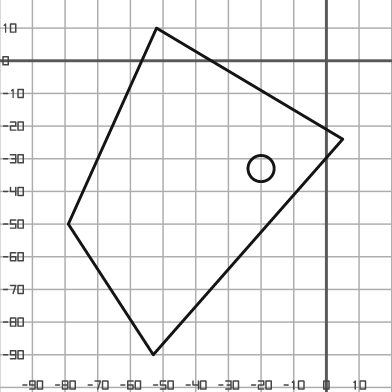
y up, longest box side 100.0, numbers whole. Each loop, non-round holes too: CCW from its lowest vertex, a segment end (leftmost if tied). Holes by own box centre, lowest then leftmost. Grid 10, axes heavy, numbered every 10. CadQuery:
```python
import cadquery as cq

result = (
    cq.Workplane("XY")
    .moveTo(-53.0, -90.0)
    .lineTo(5.0, -24.0)
    .lineTo(-52.0, 10.0)
    .lineTo(-79.0, -50.0)
    .close()
    .moveTo(-20.0, -33.0)
    .circle(4.0)
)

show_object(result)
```